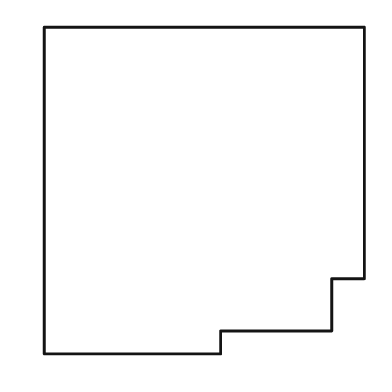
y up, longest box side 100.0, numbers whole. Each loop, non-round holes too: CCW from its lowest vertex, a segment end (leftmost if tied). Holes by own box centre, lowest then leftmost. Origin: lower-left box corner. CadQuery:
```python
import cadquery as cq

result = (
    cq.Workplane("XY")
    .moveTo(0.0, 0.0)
    .lineTo(54.0, 0.0)
    .lineTo(54.0, 7.0)
    .lineTo(88.0, 7.0)
    .lineTo(88.0, 23.0)
    .lineTo(98.0, 23.0)
    .lineTo(98.0, 100.0)
    .lineTo(0.0, 100.0)
    .close()
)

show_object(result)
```